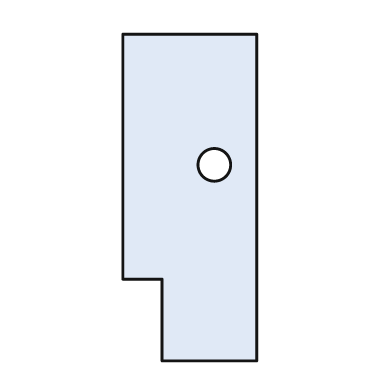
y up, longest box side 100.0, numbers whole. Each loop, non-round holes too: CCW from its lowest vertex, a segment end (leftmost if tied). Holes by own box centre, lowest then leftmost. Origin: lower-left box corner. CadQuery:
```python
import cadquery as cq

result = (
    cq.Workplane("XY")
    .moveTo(12.0, 0.0)
    .lineTo(41.0, 0.0)
    .lineTo(41.0, 100.0)
    .lineTo(0.0, 100.0)
    .lineTo(0.0, 25.0)
    .lineTo(12.0, 25.0)
    .close()
    .moveTo(28.0, 60.0)
    .circle(5.0)
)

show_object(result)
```